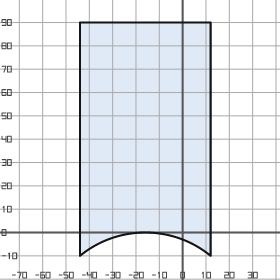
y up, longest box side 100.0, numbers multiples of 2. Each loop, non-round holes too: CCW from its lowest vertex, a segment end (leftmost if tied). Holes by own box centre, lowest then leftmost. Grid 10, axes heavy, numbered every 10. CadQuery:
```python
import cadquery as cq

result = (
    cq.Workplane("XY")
    .moveTo(-44.0, -10.0)
    .threePointArc((-16.0, 0.0), (12.0, -10.0))
    .lineTo(12.0, 90.0)
    .lineTo(-44.0, 90.0)
    .close()
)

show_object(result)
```